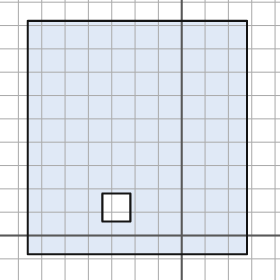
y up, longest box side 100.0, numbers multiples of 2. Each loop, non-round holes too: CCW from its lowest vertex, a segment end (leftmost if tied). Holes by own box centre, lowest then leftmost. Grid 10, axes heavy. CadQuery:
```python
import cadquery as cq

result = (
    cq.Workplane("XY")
    .moveTo(-66.0, -8.0)
    .lineTo(28.0, -8.0)
    .lineTo(28.0, 92.0)
    .lineTo(-66.0, 92.0)
    .close()
    .moveTo(-34.0, 6.0)
    .lineTo(-22.0, 6.0)
    .lineTo(-22.0, 18.0)
    .lineTo(-34.0, 18.0)
    .close()
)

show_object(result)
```